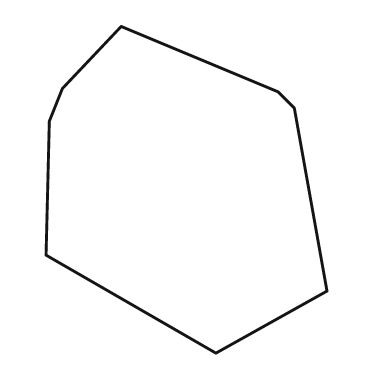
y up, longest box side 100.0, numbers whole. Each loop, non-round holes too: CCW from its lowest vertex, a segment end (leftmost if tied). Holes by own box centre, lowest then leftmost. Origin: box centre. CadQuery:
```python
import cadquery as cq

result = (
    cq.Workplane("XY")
    .moveTo(9.0, -50.0)
    .lineTo(43.0, -31.0)
    .lineTo(33.0, 25.0)
    .lineTo(28.0, 30.0)
    .lineTo(-20.0, 50.0)
    .lineTo(-38.0, 31.0)
    .lineTo(-42.0, 21.0)
    .lineTo(-43.0, -20.0)
    .close()
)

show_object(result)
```